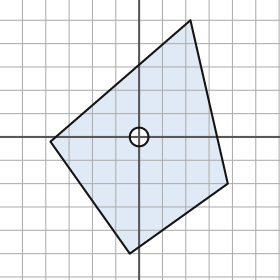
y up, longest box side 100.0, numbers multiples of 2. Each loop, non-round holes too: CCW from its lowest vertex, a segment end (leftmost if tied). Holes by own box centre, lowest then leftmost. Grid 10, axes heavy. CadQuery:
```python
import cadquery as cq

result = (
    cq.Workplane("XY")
    .moveTo(-4.0, -50.0)
    .lineTo(38.0, -20.0)
    .lineTo(22.0, 50.0)
    .lineTo(-38.0, -2.0)
    .close()
    .moveTo(0.0, 0.0)
    .circle(4.0)
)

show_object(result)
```